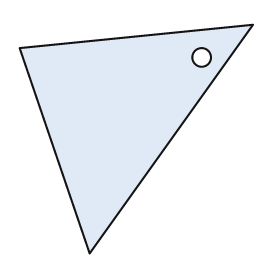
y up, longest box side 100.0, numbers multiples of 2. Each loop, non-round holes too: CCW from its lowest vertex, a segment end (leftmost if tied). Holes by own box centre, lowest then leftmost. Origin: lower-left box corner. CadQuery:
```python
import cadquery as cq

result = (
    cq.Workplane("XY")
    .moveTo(30.0, 0.0)
    .lineTo(100.0, 98.0)
    .lineTo(0.0, 88.0)
    .close()
    .moveTo(78.0, 84.0)
    .circle(4.0)
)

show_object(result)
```